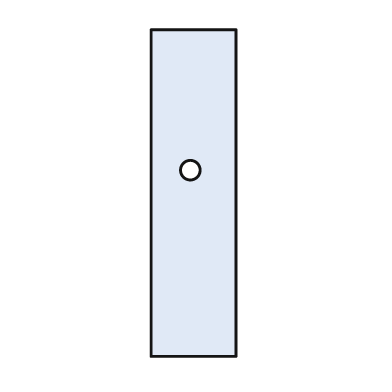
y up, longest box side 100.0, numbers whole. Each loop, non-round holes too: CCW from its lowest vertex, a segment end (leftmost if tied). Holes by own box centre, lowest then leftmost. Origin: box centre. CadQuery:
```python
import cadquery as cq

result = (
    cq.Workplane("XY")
    .moveTo(-13.0, -50.0)
    .lineTo(13.0, -50.0)
    .lineTo(13.0, 50.0)
    .lineTo(-13.0, 50.0)
    .close()
    .moveTo(-1.0, 7.0)
    .circle(3.0)
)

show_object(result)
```